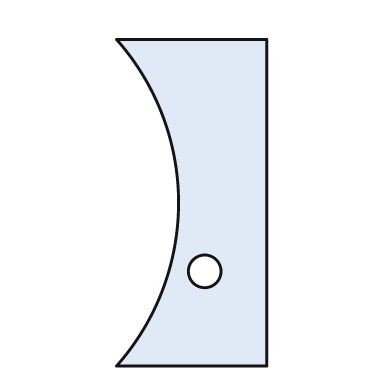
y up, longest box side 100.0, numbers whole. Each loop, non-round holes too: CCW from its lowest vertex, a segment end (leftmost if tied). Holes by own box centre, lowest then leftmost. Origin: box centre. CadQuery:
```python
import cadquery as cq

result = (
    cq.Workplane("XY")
    .moveTo(-23.0, -50.0)
    .lineTo(23.0, -50.0)
    .lineTo(23.0, 50.0)
    .lineTo(-23.0, 50.0)
    .threePointArc((-4.0, 0.0), (-23.0, -50.0))
    .close()
    .moveTo(4.0, -21.0)
    .circle(5.0)
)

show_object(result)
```